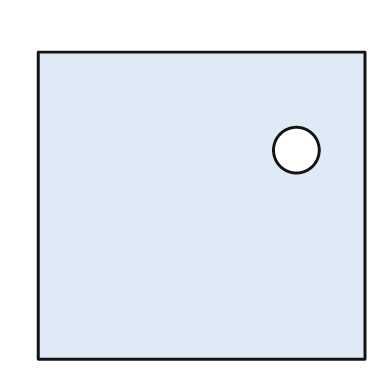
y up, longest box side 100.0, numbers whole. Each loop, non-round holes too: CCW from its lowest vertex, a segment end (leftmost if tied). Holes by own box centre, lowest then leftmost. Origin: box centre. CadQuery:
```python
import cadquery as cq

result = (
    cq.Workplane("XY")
    .moveTo(-50.0, -47.0)
    .lineTo(50.0, -47.0)
    .lineTo(50.0, 47.0)
    .lineTo(-50.0, 47.0)
    .close()
    .moveTo(29.0, 17.0)
    .circle(7.0)
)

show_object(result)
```